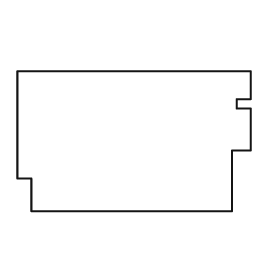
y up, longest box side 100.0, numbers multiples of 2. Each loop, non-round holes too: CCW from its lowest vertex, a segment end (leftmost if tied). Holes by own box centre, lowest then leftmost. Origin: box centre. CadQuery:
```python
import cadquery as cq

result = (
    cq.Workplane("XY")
    .moveTo(-44.0, -30.0)
    .lineTo(42.0, -30.0)
    .lineTo(42.0, -4.0)
    .lineTo(50.0, -4.0)
    .lineTo(50.0, 14.0)
    .lineTo(44.0, 14.0)
    .lineTo(44.0, 18.0)
    .lineTo(50.0, 18.0)
    .lineTo(50.0, 30.0)
    .lineTo(-50.0, 30.0)
    .lineTo(-50.0, -16.0)
    .lineTo(-44.0, -16.0)
    .close()
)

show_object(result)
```